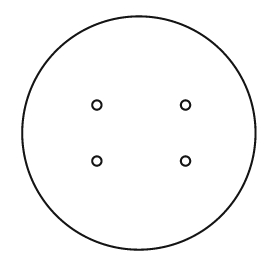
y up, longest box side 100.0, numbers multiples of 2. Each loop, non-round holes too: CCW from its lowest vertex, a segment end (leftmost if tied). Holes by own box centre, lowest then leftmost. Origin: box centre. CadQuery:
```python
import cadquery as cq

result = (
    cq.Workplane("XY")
    .moveTo(0.0, 0.0)
    .circle(50.0)
    .moveTo(-18.0, -12.0)
    .circle(2.0)
    .moveTo(20.0, -12.0)
    .circle(2.0)
    .moveTo(-18.0, 12.0)
    .circle(2.0)
    .moveTo(20.0, 12.0)
    .circle(2.0)
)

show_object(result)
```